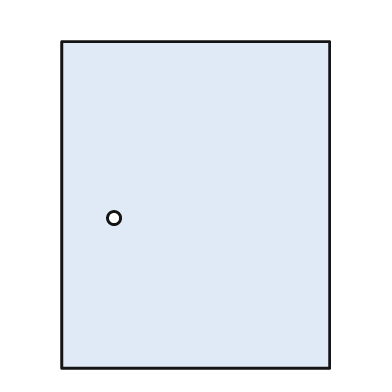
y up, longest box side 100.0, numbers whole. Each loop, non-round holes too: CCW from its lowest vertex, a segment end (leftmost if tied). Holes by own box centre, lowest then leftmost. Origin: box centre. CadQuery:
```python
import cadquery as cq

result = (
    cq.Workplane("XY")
    .moveTo(-41.0, -50.0)
    .lineTo(41.0, -50.0)
    .lineTo(41.0, 50.0)
    .lineTo(-41.0, 50.0)
    .close()
    .moveTo(-25.0, -4.0)
    .circle(2.0)
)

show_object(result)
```